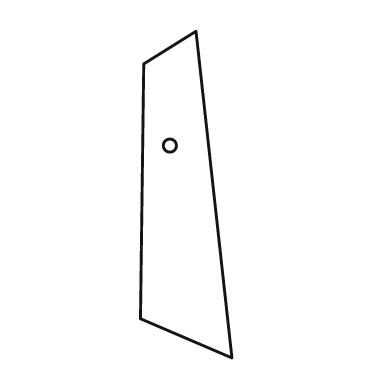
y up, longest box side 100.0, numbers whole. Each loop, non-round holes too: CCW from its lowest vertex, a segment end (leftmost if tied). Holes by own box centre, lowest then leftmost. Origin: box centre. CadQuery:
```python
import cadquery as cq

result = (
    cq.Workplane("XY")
    .moveTo(14.0, -50.0)
    .lineTo(3.0, 50.0)
    .lineTo(-13.0, 40.0)
    .lineTo(-14.0, -38.0)
    .close()
    .moveTo(-5.0, 15.0)
    .circle(2.0)
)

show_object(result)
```